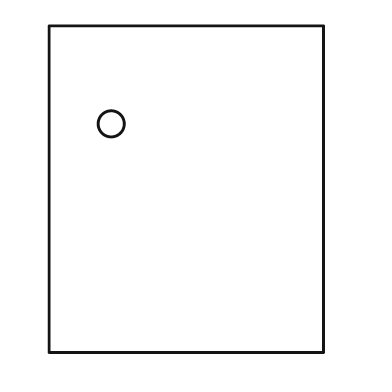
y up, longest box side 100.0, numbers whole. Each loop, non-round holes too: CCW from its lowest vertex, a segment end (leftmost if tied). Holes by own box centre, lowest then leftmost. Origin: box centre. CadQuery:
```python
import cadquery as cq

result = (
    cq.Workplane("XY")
    .moveTo(-42.0, -50.0)
    .lineTo(42.0, -50.0)
    .lineTo(42.0, 50.0)
    .lineTo(-42.0, 50.0)
    .close()
    .moveTo(-23.0, 20.0)
    .circle(4.0)
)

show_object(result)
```